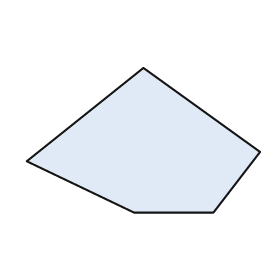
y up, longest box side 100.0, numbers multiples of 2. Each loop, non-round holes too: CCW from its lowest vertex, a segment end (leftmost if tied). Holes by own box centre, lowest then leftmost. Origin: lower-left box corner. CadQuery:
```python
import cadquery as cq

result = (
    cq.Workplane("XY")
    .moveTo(46.0, 0.0)
    .lineTo(80.0, 0.0)
    .lineTo(100.0, 26.0)
    .lineTo(50.0, 62.0)
    .lineTo(0.0, 22.0)
    .close()
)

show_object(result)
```